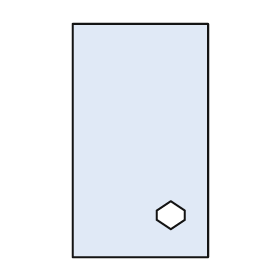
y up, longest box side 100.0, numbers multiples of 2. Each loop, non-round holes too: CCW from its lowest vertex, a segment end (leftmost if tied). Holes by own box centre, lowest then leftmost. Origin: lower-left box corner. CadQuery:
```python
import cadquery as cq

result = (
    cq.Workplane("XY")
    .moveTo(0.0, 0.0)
    .lineTo(58.0, 0.0)
    .lineTo(58.0, 100.0)
    .lineTo(0.0, 100.0)
    .close()
    .moveTo(42.0, 12.0)
    .lineTo(48.0, 16.0)
    .lineTo(48.0, 20.0)
    .lineTo(42.0, 24.0)
    .lineTo(36.0, 20.0)
    .lineTo(36.0, 16.0)
    .close()
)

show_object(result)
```